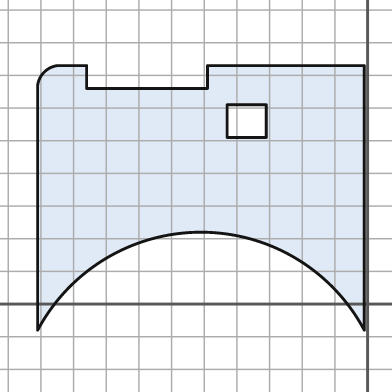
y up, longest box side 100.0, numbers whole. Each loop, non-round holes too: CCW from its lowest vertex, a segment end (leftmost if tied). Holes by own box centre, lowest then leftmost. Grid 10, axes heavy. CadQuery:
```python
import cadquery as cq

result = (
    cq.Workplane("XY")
    .moveTo(-101.0, -8.0)
    .threePointArc((-51.0, 22.0), (-1.0, -8.0))
    .lineTo(-1.0, 73.0)
    .lineTo(-49.0, 73.0)
    .lineTo(-49.0, 66.0)
    .lineTo(-86.0, 66.0)
    .lineTo(-86.0, 73.0)
    .lineTo(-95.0, 73.0)
    .threePointArc((-99.0, 71.0), (-101.0, 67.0))
    .close()
    .moveTo(-43.0, 51.0)
    .lineTo(-31.0, 51.0)
    .lineTo(-31.0, 61.0)
    .lineTo(-43.0, 61.0)
    .close()
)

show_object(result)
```